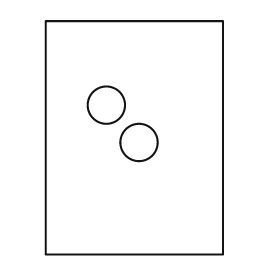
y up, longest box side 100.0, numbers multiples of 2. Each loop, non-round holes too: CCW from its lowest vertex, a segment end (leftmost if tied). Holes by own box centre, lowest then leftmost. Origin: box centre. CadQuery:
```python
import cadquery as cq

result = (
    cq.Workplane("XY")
    .moveTo(-38.0, -50.0)
    .lineTo(38.0, -50.0)
    .lineTo(38.0, 50.0)
    .lineTo(-38.0, 50.0)
    .close()
    .moveTo(2.0, -2.0)
    .circle(8.0)
    .moveTo(-12.0, 14.0)
    .circle(8.0)
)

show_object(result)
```